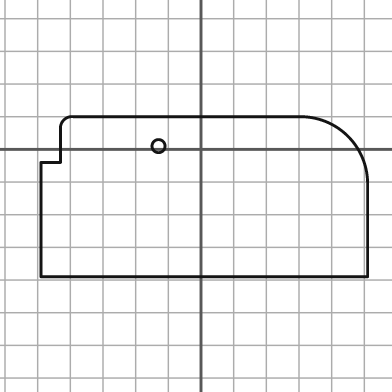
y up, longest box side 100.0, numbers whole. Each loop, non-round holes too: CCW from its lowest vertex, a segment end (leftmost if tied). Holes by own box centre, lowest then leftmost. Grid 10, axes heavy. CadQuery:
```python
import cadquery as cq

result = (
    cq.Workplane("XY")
    .moveTo(-49.0, -39.0)
    .lineTo(51.0, -39.0)
    .lineTo(51.0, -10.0)
    .threePointArc((45.0, 4.0), (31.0, 10.0))
    .lineTo(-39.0, 10.0)
    .threePointArc((-42.0, 9.0), (-43.0, 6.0))
    .lineTo(-43.0, -4.0)
    .lineTo(-49.0, -4.0)
    .close()
    .moveTo(-13.0, 1.0)
    .circle(2.0)
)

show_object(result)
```